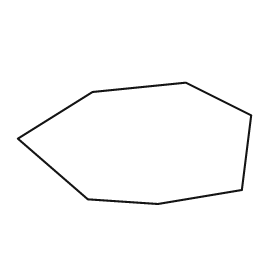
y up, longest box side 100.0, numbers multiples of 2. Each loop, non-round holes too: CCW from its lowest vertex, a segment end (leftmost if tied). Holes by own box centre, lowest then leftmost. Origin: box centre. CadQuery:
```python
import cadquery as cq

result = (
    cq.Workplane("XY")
    .moveTo(10.0, -26.0)
    .lineTo(46.0, -20.0)
    .lineTo(50.0, 12.0)
    .lineTo(22.0, 26.0)
    .lineTo(-18.0, 22.0)
    .lineTo(-50.0, 2.0)
    .lineTo(-20.0, -24.0)
    .close()
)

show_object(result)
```